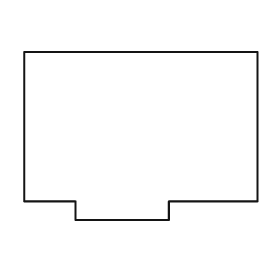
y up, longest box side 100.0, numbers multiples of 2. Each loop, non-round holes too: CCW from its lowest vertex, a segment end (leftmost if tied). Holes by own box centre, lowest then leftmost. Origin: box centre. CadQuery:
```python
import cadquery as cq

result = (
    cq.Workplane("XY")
    .moveTo(-28.0, -36.0)
    .lineTo(12.0, -36.0)
    .lineTo(12.0, -28.0)
    .lineTo(50.0, -28.0)
    .lineTo(50.0, 36.0)
    .lineTo(-50.0, 36.0)
    .lineTo(-50.0, -28.0)
    .lineTo(-28.0, -28.0)
    .close()
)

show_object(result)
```